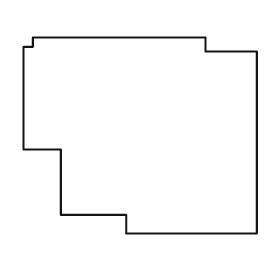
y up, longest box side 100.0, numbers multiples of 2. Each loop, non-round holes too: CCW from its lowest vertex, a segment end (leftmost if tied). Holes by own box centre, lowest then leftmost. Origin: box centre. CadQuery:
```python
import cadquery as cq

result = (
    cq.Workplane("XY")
    .moveTo(-6.0, -42.0)
    .lineTo(50.0, -42.0)
    .lineTo(50.0, 36.0)
    .lineTo(28.0, 36.0)
    .lineTo(28.0, 42.0)
    .lineTo(-46.0, 42.0)
    .lineTo(-46.0, 38.0)
    .lineTo(-50.0, 38.0)
    .lineTo(-50.0, -6.0)
    .lineTo(-34.0, -6.0)
    .lineTo(-34.0, -34.0)
    .lineTo(-6.0, -34.0)
    .close()
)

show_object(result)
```